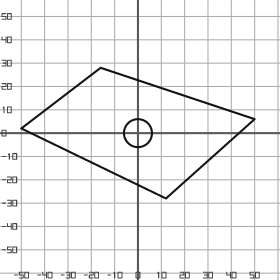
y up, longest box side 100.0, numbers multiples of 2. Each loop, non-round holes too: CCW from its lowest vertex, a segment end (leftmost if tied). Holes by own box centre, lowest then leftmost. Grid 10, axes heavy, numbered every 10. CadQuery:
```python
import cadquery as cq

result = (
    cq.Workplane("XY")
    .moveTo(12.0, -28.0)
    .lineTo(50.0, 6.0)
    .lineTo(-16.0, 28.0)
    .lineTo(-50.0, 2.0)
    .close()
    .moveTo(0.0, 0.0)
    .circle(6.0)
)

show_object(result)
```